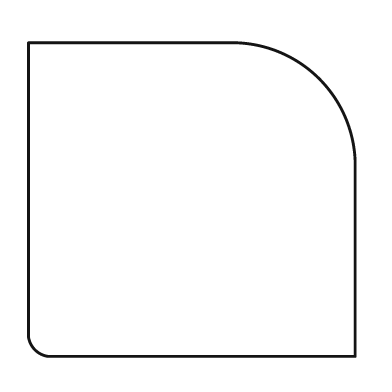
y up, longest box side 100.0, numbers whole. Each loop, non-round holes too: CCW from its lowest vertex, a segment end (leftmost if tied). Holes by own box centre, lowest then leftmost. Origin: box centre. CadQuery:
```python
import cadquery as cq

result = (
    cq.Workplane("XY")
    .moveTo(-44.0, -48.0)
    .lineTo(50.0, -48.0)
    .lineTo(50.0, 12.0)
    .threePointArc((39.0, 37.0), (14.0, 48.0))
    .lineTo(-50.0, 48.0)
    .lineTo(-50.0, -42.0)
    .threePointArc((-48.0, -46.0), (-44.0, -48.0))
    .close()
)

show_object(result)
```